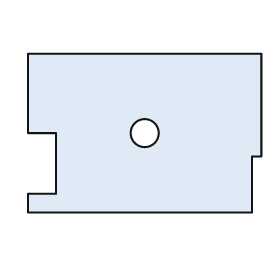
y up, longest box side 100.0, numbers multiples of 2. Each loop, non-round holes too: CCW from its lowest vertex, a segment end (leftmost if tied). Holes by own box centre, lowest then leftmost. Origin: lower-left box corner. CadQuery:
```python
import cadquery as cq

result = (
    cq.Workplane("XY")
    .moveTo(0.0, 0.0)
    .lineTo(96.0, 0.0)
    .lineTo(96.0, 24.0)
    .lineTo(100.0, 24.0)
    .lineTo(100.0, 68.0)
    .lineTo(0.0, 68.0)
    .lineTo(0.0, 34.0)
    .lineTo(12.0, 34.0)
    .lineTo(12.0, 8.0)
    .lineTo(0.0, 8.0)
    .close()
    .moveTo(50.0, 34.0)
    .circle(6.0)
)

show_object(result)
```